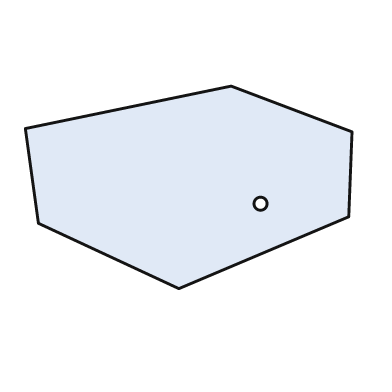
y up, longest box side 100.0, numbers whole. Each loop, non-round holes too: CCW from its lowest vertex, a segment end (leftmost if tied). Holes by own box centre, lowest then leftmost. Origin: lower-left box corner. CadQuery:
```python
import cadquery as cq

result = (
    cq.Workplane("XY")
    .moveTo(47.0, 0.0)
    .lineTo(99.0, 22.0)
    .lineTo(100.0, 48.0)
    .lineTo(63.0, 62.0)
    .lineTo(0.0, 49.0)
    .lineTo(4.0, 20.0)
    .close()
    .moveTo(72.0, 26.0)
    .circle(2.0)
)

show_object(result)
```